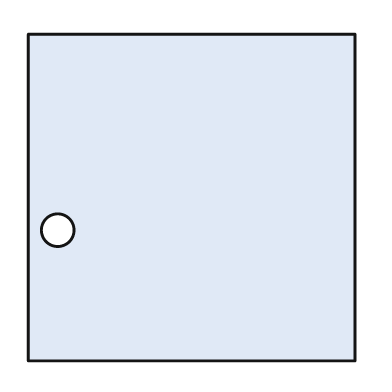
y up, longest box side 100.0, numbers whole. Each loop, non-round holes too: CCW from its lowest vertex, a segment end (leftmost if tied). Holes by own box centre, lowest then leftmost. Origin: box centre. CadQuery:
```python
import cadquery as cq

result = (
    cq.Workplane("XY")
    .moveTo(-50.0, -50.0)
    .lineTo(50.0, -50.0)
    .lineTo(50.0, 50.0)
    .lineTo(-50.0, 50.0)
    .close()
    .moveTo(-41.0, -10.0)
    .circle(5.0)
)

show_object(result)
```